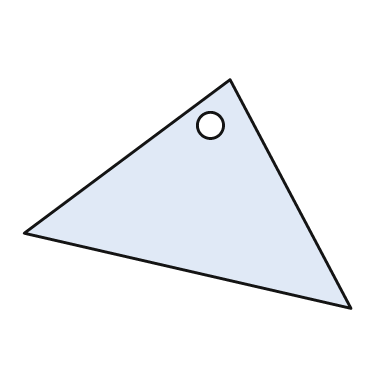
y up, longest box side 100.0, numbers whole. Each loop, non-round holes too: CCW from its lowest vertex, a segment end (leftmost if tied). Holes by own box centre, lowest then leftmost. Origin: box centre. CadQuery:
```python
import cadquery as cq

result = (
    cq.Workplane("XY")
    .moveTo(50.0, -35.0)
    .lineTo(13.0, 35.0)
    .lineTo(-50.0, -12.0)
    .close()
    .moveTo(7.0, 21.0)
    .circle(4.0)
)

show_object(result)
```